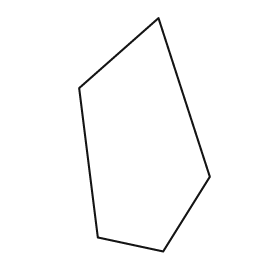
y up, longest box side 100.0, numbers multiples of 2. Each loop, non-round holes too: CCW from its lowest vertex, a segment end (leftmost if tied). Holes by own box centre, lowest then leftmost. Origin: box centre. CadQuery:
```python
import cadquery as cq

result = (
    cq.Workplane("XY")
    .moveTo(8.0, -50.0)
    .lineTo(28.0, -18.0)
    .lineTo(6.0, 50.0)
    .lineTo(-28.0, 20.0)
    .lineTo(-20.0, -44.0)
    .close()
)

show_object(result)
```